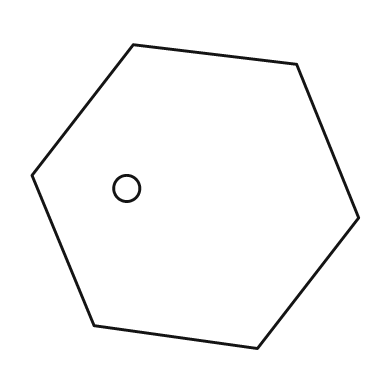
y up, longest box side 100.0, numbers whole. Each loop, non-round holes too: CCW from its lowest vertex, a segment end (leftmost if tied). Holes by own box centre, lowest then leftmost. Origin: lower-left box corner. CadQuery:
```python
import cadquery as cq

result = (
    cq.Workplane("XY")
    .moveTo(69.0, 0.0)
    .lineTo(100.0, 40.0)
    .lineTo(81.0, 87.0)
    .lineTo(31.0, 93.0)
    .lineTo(0.0, 53.0)
    .lineTo(19.0, 7.0)
    .close()
    .moveTo(29.0, 49.0)
    .circle(4.0)
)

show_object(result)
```